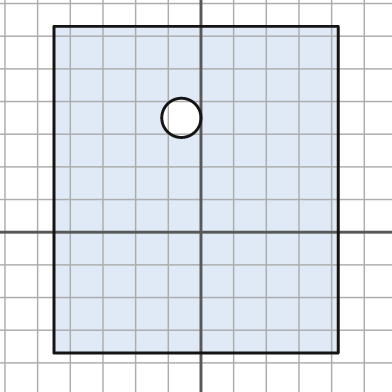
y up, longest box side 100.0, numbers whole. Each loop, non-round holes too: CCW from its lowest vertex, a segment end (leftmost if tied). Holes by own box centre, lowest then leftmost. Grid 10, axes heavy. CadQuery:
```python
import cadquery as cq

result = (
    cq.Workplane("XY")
    .moveTo(-45.0, -37.0)
    .lineTo(42.0, -37.0)
    .lineTo(42.0, 63.0)
    .lineTo(-45.0, 63.0)
    .close()
    .moveTo(-6.0, 35.0)
    .circle(6.0)
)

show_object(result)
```